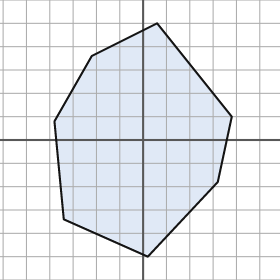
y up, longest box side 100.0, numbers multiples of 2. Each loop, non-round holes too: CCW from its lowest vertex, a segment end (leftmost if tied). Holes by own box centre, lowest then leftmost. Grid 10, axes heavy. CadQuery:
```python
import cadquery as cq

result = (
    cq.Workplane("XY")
    .moveTo(2.0, -50.0)
    .lineTo(32.0, -18.0)
    .lineTo(38.0, 10.0)
    .lineTo(6.0, 50.0)
    .lineTo(-22.0, 36.0)
    .lineTo(-38.0, 8.0)
    .lineTo(-34.0, -34.0)
    .close()
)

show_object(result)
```